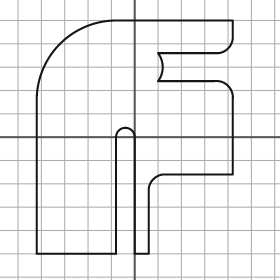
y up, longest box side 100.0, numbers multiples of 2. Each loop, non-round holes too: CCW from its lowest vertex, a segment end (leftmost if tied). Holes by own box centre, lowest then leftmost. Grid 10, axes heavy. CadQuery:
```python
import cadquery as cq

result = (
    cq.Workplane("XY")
    .moveTo(-42.0, -50.0)
    .lineTo(-8.0, -50.0)
    .lineTo(-8.0, 0.0)
    .threePointArc((-4.0, 4.0), (0.0, 0.0))
    .lineTo(0.0, -50.0)
    .lineTo(6.0, -50.0)
    .lineTo(6.0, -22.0)
    .threePointArc((8.0, -18.0), (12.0, -16.0))
    .lineTo(42.0, -16.0)
    .lineTo(42.0, 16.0)
    .threePointArc((40.0, 22.0), (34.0, 24.0))
    .lineTo(10.0, 24.0)
    .threePointArc((12.0, 30.0), (10.0, 36.0))
    .lineTo(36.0, 36.0)
    .threePointArc((40.0, 38.0), (42.0, 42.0))
    .lineTo(42.0, 50.0)
    .lineTo(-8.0, 50.0)
    .threePointArc((-32.0, 40.0), (-42.0, 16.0))
    .close()
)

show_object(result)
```